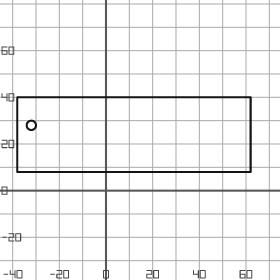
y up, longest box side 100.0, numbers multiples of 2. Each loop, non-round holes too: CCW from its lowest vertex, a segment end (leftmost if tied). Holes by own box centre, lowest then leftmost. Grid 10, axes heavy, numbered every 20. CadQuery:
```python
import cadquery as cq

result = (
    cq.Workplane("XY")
    .moveTo(-38.0, 8.0)
    .lineTo(62.0, 8.0)
    .lineTo(62.0, 40.0)
    .lineTo(-38.0, 40.0)
    .close()
    .moveTo(-32.0, 28.0)
    .circle(2.0)
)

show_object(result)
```